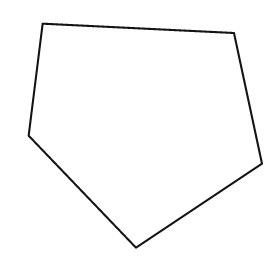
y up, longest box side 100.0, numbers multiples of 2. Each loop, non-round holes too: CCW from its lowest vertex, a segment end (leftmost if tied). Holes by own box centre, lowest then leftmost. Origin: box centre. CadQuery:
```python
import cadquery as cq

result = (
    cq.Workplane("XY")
    .moveTo(-4.0, -48.0)
    .lineTo(50.0, -12.0)
    .lineTo(38.0, 44.0)
    .lineTo(-44.0, 48.0)
    .lineTo(-50.0, 0.0)
    .close()
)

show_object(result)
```